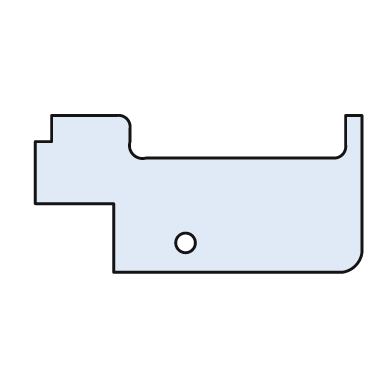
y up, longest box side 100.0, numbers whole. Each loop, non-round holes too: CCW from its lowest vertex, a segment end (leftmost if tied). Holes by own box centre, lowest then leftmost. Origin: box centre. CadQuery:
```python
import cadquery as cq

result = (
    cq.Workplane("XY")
    .moveTo(-26.0, -24.0)
    .lineTo(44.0, -24.0)
    .threePointArc((48.0, -22.0), (50.0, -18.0))
    .lineTo(50.0, 24.0)
    .lineTo(45.0, 24.0)
    .lineTo(45.0, 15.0)
    .threePointArc((44.0, 12.0), (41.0, 11.0))
    .lineTo(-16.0, 11.0)
    .threePointArc((-20.0, 12.0), (-21.0, 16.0))
    .lineTo(-21.0, 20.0)
    .threePointArc((-22.0, 23.0), (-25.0, 24.0))
    .lineTo(-45.0, 24.0)
    .lineTo(-45.0, 16.0)
    .lineTo(-50.0, 16.0)
    .lineTo(-50.0, -3.0)
    .lineTo(-26.0, -3.0)
    .close()
    .moveTo(-4.0, -15.0)
    .circle(3.0)
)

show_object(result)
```